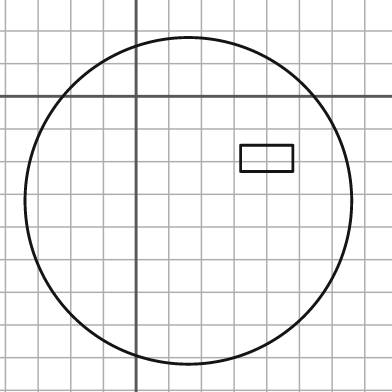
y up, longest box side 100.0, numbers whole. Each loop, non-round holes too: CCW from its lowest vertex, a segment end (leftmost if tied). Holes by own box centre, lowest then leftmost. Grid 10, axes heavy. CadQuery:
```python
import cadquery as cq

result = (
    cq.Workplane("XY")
    .moveTo(16.0, -32.0)
    .circle(50.0)
    .moveTo(32.0, -23.0)
    .lineTo(48.0, -23.0)
    .lineTo(48.0, -15.0)
    .lineTo(32.0, -15.0)
    .close()
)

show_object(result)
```